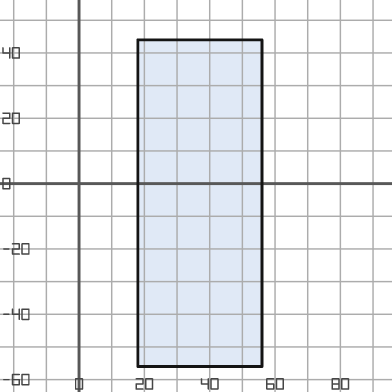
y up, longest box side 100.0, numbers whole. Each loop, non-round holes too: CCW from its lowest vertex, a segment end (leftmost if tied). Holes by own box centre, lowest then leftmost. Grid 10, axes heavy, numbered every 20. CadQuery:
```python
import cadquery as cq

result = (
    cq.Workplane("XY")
    .moveTo(18.0, -56.0)
    .lineTo(56.0, -56.0)
    .lineTo(56.0, 44.0)
    .lineTo(18.0, 44.0)
    .close()
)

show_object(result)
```